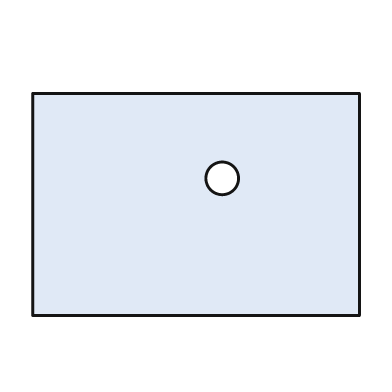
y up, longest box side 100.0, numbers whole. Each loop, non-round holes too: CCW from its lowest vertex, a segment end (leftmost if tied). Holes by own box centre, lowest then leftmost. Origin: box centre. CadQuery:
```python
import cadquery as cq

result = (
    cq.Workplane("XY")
    .moveTo(-50.0, -34.0)
    .lineTo(50.0, -34.0)
    .lineTo(50.0, 34.0)
    .lineTo(-50.0, 34.0)
    .close()
    .moveTo(8.0, 8.0)
    .circle(5.0)
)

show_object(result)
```